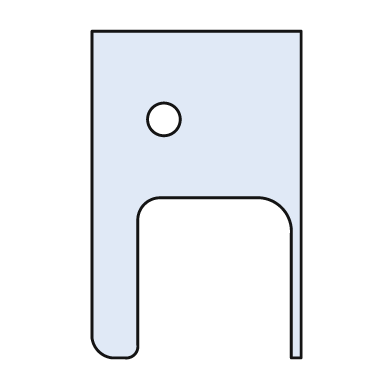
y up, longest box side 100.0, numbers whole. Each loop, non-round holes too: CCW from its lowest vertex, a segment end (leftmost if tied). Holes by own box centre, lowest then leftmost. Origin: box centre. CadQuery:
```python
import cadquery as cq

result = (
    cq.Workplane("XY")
    .moveTo(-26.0, -50.0)
    .lineTo(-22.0, -50.0)
    .threePointArc((-19.0, -49.0), (-18.0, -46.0))
    .lineTo(-18.0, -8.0)
    .threePointArc((-16.0, -3.0), (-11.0, -1.0))
    .lineTo(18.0, -1.0)
    .threePointArc((26.0, -4.0), (29.0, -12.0))
    .lineTo(29.0, -50.0)
    .lineTo(32.0, -50.0)
    .lineTo(32.0, 50.0)
    .lineTo(-32.0, 50.0)
    .lineTo(-32.0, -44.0)
    .threePointArc((-30.0, -48.0), (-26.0, -50.0))
    .close()
    .moveTo(-10.0, 23.0)
    .circle(5.0)
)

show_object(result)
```